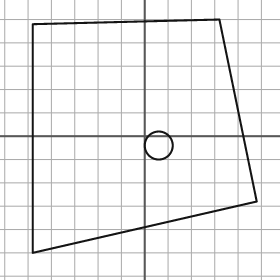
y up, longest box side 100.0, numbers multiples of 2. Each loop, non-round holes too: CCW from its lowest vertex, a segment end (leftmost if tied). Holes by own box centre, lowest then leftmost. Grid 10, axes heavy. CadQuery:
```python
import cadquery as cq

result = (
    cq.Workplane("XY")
    .moveTo(-48.0, -50.0)
    .lineTo(48.0, -28.0)
    .lineTo(32.0, 50.0)
    .lineTo(-48.0, 48.0)
    .close()
    .moveTo(6.0, -4.0)
    .circle(6.0)
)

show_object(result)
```